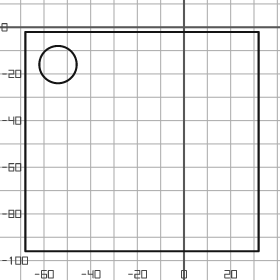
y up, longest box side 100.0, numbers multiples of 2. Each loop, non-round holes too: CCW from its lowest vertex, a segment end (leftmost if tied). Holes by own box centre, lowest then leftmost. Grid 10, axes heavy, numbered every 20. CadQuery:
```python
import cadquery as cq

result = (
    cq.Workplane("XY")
    .moveTo(-68.0, -96.0)
    .lineTo(32.0, -96.0)
    .lineTo(32.0, -2.0)
    .lineTo(-68.0, -2.0)
    .close()
    .moveTo(-54.0, -16.0)
    .circle(8.0)
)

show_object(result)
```